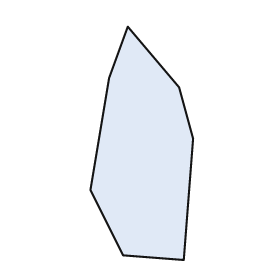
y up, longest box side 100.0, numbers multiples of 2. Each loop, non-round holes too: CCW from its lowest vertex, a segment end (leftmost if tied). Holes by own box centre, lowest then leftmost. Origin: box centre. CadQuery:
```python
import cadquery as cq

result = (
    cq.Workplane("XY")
    .moveTo(18.0, -50.0)
    .lineTo(22.0, 2.0)
    .lineTo(16.0, 24.0)
    .lineTo(-6.0, 50.0)
    .lineTo(-14.0, 28.0)
    .lineTo(-22.0, -20.0)
    .lineTo(-8.0, -48.0)
    .close()
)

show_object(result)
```